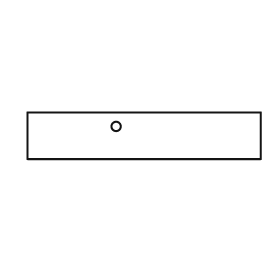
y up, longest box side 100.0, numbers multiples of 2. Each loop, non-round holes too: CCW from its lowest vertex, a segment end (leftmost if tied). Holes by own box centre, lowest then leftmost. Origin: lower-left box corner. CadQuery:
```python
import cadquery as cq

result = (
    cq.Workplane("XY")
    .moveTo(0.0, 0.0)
    .lineTo(100.0, 0.0)
    .lineTo(100.0, 20.0)
    .lineTo(0.0, 20.0)
    .close()
    .moveTo(38.0, 14.0)
    .circle(2.0)
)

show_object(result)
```